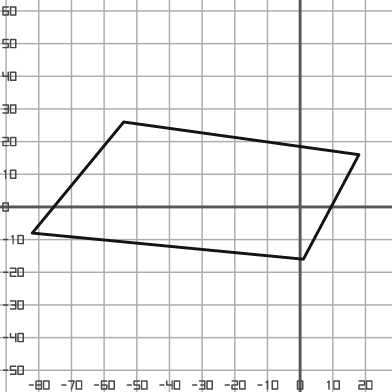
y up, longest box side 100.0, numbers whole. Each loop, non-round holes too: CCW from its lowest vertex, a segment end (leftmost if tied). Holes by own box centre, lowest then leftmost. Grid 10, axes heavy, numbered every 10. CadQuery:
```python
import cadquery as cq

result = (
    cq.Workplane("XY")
    .moveTo(1.0, -16.0)
    .lineTo(18.0, 16.0)
    .lineTo(-54.0, 26.0)
    .lineTo(-82.0, -8.0)
    .close()
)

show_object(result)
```